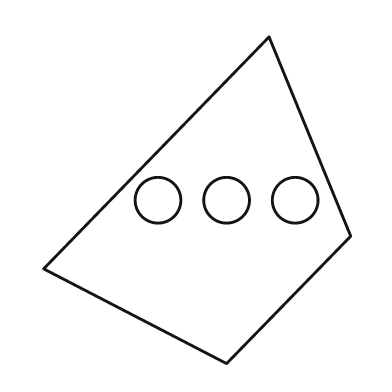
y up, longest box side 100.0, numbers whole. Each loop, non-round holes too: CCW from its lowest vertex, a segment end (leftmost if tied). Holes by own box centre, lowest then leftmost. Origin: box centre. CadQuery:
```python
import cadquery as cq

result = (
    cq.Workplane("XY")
    .moveTo(9.0, -50.0)
    .lineTo(47.0, -11.0)
    .lineTo(22.0, 50.0)
    .lineTo(-47.0, -21.0)
    .close()
    .moveTo(-12.0, 0.0)
    .circle(7.0)
    .moveTo(9.0, 0.0)
    .circle(7.0)
    .moveTo(30.0, 0.0)
    .circle(7.0)
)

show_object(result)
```